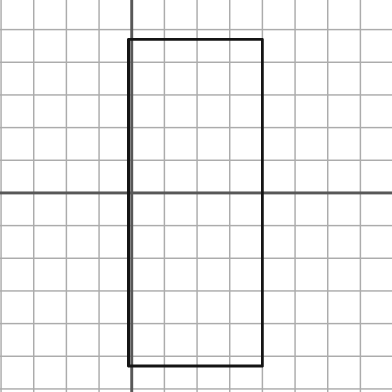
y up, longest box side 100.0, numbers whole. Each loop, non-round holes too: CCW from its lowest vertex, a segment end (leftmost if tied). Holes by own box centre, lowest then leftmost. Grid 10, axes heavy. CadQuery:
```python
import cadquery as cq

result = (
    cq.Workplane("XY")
    .moveTo(-1.0, -53.0)
    .lineTo(40.0, -53.0)
    .lineTo(40.0, 47.0)
    .lineTo(-1.0, 47.0)
    .close()
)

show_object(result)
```